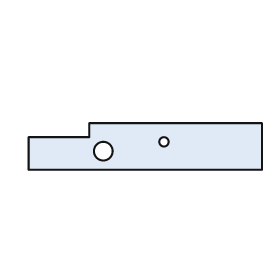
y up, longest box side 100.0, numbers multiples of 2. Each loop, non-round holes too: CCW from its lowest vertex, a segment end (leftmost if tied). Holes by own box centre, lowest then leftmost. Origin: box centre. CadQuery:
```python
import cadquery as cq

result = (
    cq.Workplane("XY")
    .moveTo(-50.0, -10.0)
    .lineTo(50.0, -10.0)
    .lineTo(50.0, 10.0)
    .lineTo(-24.0, 10.0)
    .lineTo(-24.0, 4.0)
    .lineTo(-50.0, 4.0)
    .close()
    .moveTo(-18.0, -2.0)
    .circle(4.0)
    .moveTo(8.0, 2.0)
    .circle(2.0)
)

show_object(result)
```